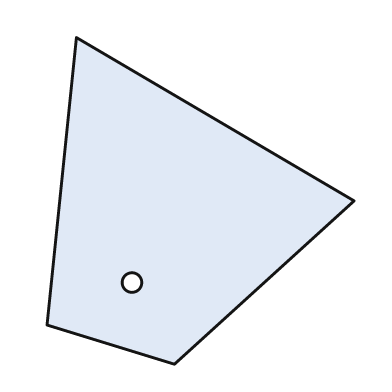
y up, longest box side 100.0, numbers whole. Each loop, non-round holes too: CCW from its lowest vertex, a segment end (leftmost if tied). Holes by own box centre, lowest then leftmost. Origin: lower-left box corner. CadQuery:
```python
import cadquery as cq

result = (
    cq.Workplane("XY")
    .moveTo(39.0, 0.0)
    .lineTo(94.0, 50.0)
    .lineTo(9.0, 100.0)
    .lineTo(0.0, 12.0)
    .close()
    .moveTo(26.0, 25.0)
    .circle(3.0)
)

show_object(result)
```